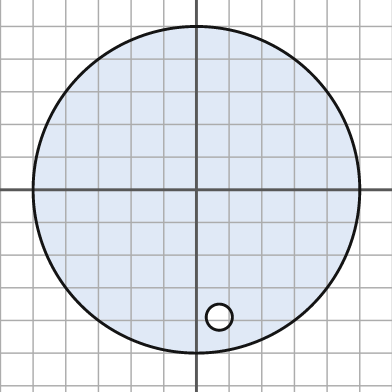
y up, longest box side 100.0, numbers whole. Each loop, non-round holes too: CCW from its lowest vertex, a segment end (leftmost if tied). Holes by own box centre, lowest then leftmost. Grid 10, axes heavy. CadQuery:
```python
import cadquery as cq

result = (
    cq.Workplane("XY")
    .moveTo(0.0, 0.0)
    .circle(50.0)
    .moveTo(7.0, -39.0)
    .circle(4.0)
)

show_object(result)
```